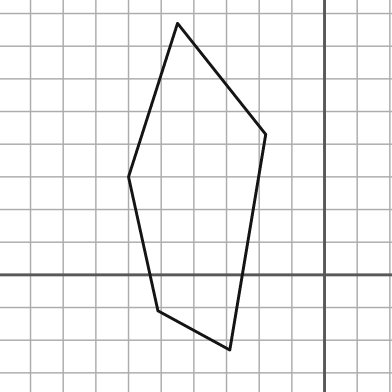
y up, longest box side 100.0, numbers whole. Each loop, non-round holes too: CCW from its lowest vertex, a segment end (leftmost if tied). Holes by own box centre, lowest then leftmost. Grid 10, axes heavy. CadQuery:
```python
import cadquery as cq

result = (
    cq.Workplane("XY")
    .moveTo(-29.0, -23.0)
    .lineTo(-18.0, 43.0)
    .lineTo(-45.0, 77.0)
    .lineTo(-60.0, 30.0)
    .lineTo(-51.0, -11.0)
    .close()
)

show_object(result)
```